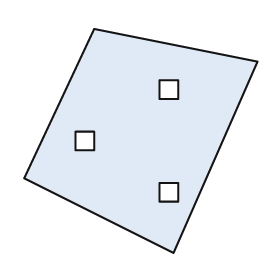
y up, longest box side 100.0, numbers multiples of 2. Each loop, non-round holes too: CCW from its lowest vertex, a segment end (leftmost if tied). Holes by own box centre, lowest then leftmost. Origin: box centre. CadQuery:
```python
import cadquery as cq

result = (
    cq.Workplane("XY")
    .moveTo(14.0, -48.0)
    .lineTo(50.0, 34.0)
    .lineTo(-20.0, 48.0)
    .lineTo(-50.0, -16.0)
    .close()
    .moveTo(8.0, -26.0)
    .lineTo(16.0, -26.0)
    .lineTo(16.0, -18.0)
    .lineTo(8.0, -18.0)
    .close()
    .moveTo(-28.0, -4.0)
    .lineTo(-20.0, -4.0)
    .lineTo(-20.0, 4.0)
    .lineTo(-28.0, 4.0)
    .close()
    .moveTo(8.0, 18.0)
    .lineTo(16.0, 18.0)
    .lineTo(16.0, 26.0)
    .lineTo(8.0, 26.0)
    .close()
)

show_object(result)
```